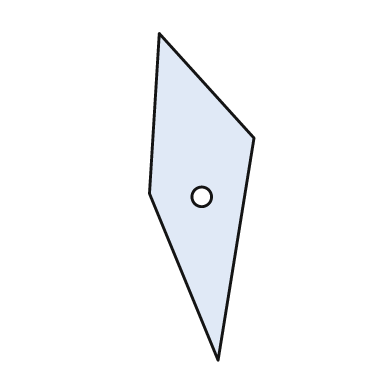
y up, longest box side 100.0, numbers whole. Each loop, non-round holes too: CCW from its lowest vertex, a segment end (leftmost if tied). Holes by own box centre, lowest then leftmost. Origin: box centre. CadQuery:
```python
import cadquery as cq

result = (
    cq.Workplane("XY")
    .moveTo(5.0, -50.0)
    .lineTo(16.0, 18.0)
    .lineTo(-13.0, 50.0)
    .lineTo(-16.0, 1.0)
    .close()
    .moveTo(0.0, 0.0)
    .circle(3.0)
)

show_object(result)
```